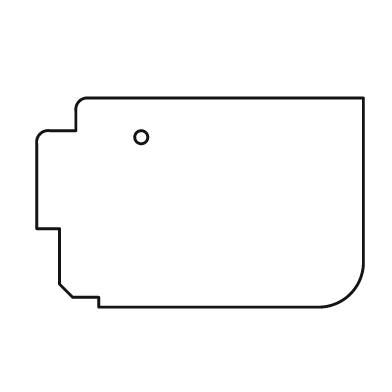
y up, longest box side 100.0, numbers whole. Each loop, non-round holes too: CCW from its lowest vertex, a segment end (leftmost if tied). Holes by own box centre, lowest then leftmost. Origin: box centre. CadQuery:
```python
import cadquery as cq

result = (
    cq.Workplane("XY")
    .moveTo(-31.0, -32.0)
    .lineTo(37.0, -32.0)
    .threePointArc((46.0, -28.0), (50.0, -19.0))
    .lineTo(50.0, 32.0)
    .lineTo(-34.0, 32.0)
    .threePointArc((-37.0, 31.0), (-38.0, 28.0))
    .lineTo(-38.0, 22.0)
    .lineTo(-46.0, 22.0)
    .threePointArc((-49.0, 21.0), (-50.0, 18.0))
    .lineTo(-50.0, -8.0)
    .lineTo(-43.0, -8.0)
    .lineTo(-43.0, -25.0)
    .lineTo(-39.0, -29.0)
    .lineTo(-31.0, -29.0)
    .close()
    .moveTo(-18.0, 20.0)
    .circle(2.0)
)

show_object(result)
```